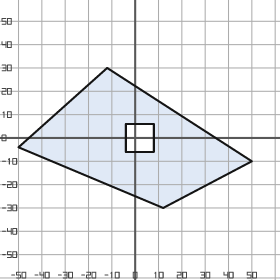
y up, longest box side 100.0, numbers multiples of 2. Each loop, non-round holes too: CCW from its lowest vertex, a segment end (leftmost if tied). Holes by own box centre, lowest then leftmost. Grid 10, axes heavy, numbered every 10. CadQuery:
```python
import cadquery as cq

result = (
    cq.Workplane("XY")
    .moveTo(12.0, -30.0)
    .lineTo(50.0, -10.0)
    .lineTo(-12.0, 30.0)
    .lineTo(-50.0, -4.0)
    .close()
    .moveTo(-4.0, -6.0)
    .lineTo(8.0, -6.0)
    .lineTo(8.0, 6.0)
    .lineTo(-4.0, 6.0)
    .close()
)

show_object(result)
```